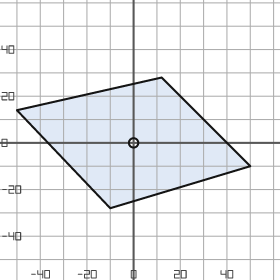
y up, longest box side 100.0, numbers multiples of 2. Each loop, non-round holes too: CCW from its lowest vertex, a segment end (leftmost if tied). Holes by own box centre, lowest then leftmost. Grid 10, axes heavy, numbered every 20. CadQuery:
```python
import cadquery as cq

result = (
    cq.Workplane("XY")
    .moveTo(-10.0, -28.0)
    .lineTo(50.0, -10.0)
    .lineTo(12.0, 28.0)
    .lineTo(-50.0, 14.0)
    .close()
    .moveTo(0.0, 0.0)
    .circle(2.0)
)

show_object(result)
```